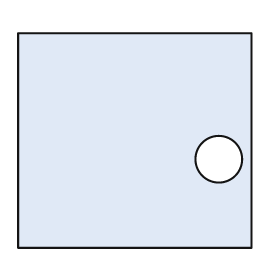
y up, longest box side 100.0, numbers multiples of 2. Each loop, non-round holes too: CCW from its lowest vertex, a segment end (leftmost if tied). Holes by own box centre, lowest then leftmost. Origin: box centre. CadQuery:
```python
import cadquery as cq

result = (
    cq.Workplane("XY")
    .moveTo(-50.0, -46.0)
    .lineTo(50.0, -46.0)
    .lineTo(50.0, 46.0)
    .lineTo(-50.0, 46.0)
    .close()
    .moveTo(36.0, -8.0)
    .circle(10.0)
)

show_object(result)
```